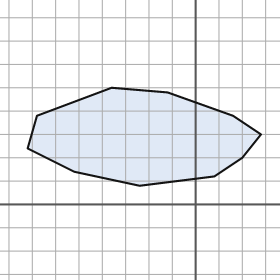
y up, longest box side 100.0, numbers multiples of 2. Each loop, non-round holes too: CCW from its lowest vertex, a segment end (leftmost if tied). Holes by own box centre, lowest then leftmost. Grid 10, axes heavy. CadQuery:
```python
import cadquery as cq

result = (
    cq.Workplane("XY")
    .moveTo(-24.0, 8.0)
    .lineTo(8.0, 12.0)
    .lineTo(20.0, 20.0)
    .lineTo(28.0, 30.0)
    .lineTo(16.0, 38.0)
    .lineTo(-12.0, 48.0)
    .lineTo(-36.0, 50.0)
    .lineTo(-68.0, 38.0)
    .lineTo(-72.0, 24.0)
    .lineTo(-52.0, 14.0)
    .close()
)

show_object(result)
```